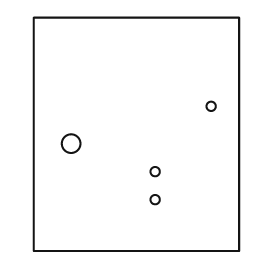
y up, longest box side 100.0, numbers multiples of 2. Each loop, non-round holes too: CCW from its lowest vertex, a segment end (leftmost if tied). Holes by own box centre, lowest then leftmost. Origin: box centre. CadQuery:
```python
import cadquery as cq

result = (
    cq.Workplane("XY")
    .moveTo(-44.0, -50.0)
    .lineTo(44.0, -50.0)
    .lineTo(44.0, 50.0)
    .lineTo(-44.0, 50.0)
    .close()
    .moveTo(8.0, -28.0)
    .circle(2.0)
    .moveTo(8.0, -16.0)
    .circle(2.0)
    .moveTo(-28.0, -4.0)
    .circle(4.0)
    .moveTo(32.0, 12.0)
    .circle(2.0)
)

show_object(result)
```